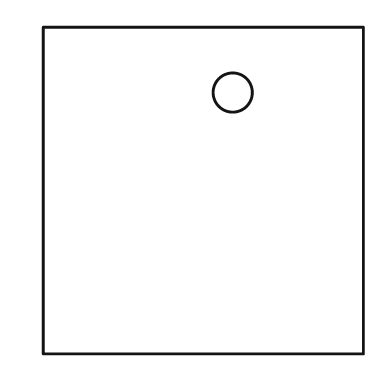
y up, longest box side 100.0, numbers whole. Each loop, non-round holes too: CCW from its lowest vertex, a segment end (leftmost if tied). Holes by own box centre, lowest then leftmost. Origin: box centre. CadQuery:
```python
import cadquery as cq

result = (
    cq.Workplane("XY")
    .moveTo(-49.0, -50.0)
    .lineTo(49.0, -50.0)
    .lineTo(49.0, 50.0)
    .lineTo(-49.0, 50.0)
    .close()
    .moveTo(9.0, 30.0)
    .circle(6.0)
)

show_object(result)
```